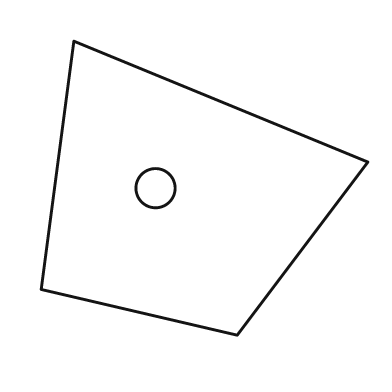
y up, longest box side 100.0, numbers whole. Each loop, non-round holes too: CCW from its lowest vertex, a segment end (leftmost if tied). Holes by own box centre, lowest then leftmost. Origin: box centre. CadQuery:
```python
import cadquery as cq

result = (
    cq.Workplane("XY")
    .moveTo(10.0, -45.0)
    .lineTo(50.0, 8.0)
    .lineTo(-40.0, 45.0)
    .lineTo(-50.0, -31.0)
    .close()
    .moveTo(-15.0, 0.0)
    .circle(6.0)
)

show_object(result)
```